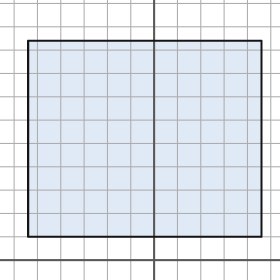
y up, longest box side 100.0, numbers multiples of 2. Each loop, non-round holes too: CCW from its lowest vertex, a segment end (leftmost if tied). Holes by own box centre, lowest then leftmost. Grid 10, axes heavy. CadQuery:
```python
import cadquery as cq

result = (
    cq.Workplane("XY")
    .moveTo(-54.0, 10.0)
    .lineTo(46.0, 10.0)
    .lineTo(46.0, 94.0)
    .lineTo(-54.0, 94.0)
    .close()
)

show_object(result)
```